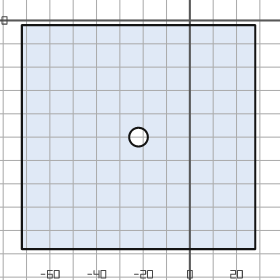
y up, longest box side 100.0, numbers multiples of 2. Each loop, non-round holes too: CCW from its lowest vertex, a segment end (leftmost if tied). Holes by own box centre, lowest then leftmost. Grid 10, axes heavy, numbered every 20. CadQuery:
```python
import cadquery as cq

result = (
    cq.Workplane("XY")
    .moveTo(-72.0, -98.0)
    .lineTo(28.0, -98.0)
    .lineTo(28.0, -2.0)
    .lineTo(-72.0, -2.0)
    .close()
    .moveTo(-22.0, -50.0)
    .circle(4.0)
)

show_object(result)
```